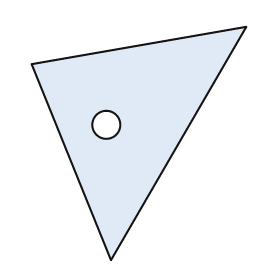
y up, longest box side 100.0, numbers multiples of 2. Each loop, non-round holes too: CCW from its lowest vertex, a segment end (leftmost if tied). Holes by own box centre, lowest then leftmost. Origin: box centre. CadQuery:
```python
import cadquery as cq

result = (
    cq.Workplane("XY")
    .moveTo(-12.0, -50.0)
    .lineTo(46.0, 50.0)
    .lineTo(-46.0, 34.0)
    .close()
    .moveTo(-14.0, 8.0)
    .circle(6.0)
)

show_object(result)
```